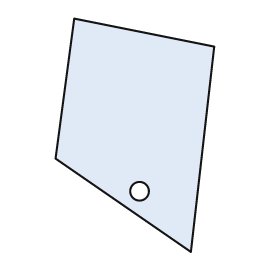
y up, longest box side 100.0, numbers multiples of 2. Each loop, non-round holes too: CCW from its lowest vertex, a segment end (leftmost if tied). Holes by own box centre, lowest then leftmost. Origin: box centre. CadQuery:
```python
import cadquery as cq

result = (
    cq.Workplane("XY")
    .moveTo(24.0, -50.0)
    .lineTo(34.0, 38.0)
    .lineTo(-26.0, 50.0)
    .lineTo(-34.0, -10.0)
    .close()
    .moveTo(2.0, -24.0)
    .circle(4.0)
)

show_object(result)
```